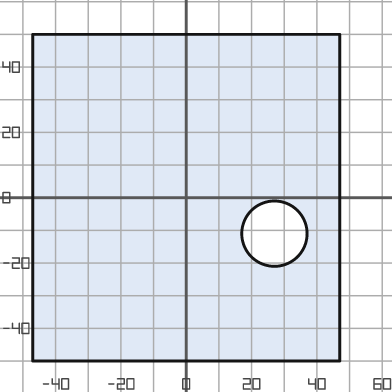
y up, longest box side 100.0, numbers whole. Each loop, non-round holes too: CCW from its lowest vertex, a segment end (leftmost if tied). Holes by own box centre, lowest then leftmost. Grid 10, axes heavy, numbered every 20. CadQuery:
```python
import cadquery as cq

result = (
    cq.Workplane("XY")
    .moveTo(-47.0, -50.0)
    .lineTo(47.0, -50.0)
    .lineTo(47.0, 50.0)
    .lineTo(-47.0, 50.0)
    .close()
    .moveTo(27.0, -11.0)
    .circle(10.0)
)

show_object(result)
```